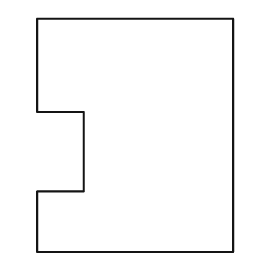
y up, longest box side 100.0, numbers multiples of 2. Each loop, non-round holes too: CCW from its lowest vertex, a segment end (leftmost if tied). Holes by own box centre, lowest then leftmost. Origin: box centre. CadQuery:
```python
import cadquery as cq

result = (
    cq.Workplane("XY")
    .moveTo(-42.0, -50.0)
    .lineTo(42.0, -50.0)
    .lineTo(42.0, 50.0)
    .lineTo(-42.0, 50.0)
    .lineTo(-42.0, 10.0)
    .lineTo(-22.0, 10.0)
    .lineTo(-22.0, -24.0)
    .lineTo(-42.0, -24.0)
    .close()
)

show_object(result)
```